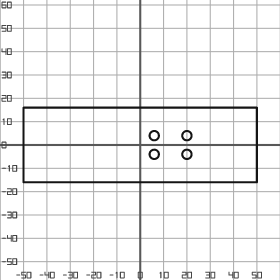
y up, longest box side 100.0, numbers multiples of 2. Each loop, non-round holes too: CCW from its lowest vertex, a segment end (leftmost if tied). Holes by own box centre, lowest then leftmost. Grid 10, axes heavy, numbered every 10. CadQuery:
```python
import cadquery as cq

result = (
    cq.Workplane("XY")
    .moveTo(-50.0, -16.0)
    .lineTo(50.0, -16.0)
    .lineTo(50.0, 16.0)
    .lineTo(-50.0, 16.0)
    .close()
    .moveTo(6.0, -4.0)
    .circle(2.0)
    .moveTo(20.0, -4.0)
    .circle(2.0)
    .moveTo(6.0, 4.0)
    .circle(2.0)
    .moveTo(20.0, 4.0)
    .circle(2.0)
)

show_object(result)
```